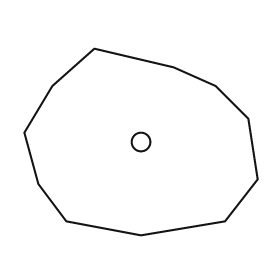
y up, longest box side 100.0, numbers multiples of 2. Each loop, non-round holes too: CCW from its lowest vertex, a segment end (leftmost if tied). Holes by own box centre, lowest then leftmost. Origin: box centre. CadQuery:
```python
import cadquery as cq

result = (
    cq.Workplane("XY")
    .moveTo(0.0, -40.0)
    .lineTo(36.0, -34.0)
    .lineTo(50.0, -16.0)
    .lineTo(46.0, 10.0)
    .lineTo(32.0, 24.0)
    .lineTo(14.0, 32.0)
    .lineTo(-20.0, 40.0)
    .lineTo(-38.0, 24.0)
    .lineTo(-50.0, 4.0)
    .lineTo(-44.0, -18.0)
    .lineTo(-32.0, -34.0)
    .close()
    .moveTo(0.0, 0.0)
    .circle(4.0)
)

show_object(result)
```